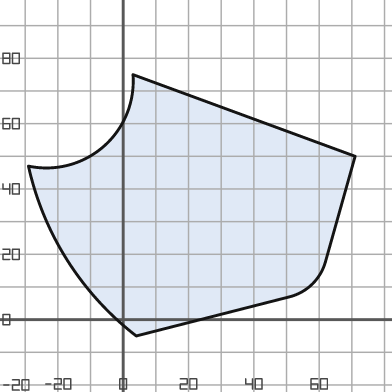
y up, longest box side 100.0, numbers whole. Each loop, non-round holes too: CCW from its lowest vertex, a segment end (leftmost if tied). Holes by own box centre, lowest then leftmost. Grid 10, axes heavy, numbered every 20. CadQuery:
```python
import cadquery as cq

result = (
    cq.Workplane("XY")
    .moveTo(4.0, -5.0)
    .lineTo(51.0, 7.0)
    .threePointArc((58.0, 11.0), (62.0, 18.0))
    .lineTo(71.0, 50.0)
    .lineTo(3.0, 75.0)
    .threePointArc((-6.0, 53.0), (-29.0, 47.0))
    .threePointArc((-17.0, 18.0), (4.0, -5.0))
    .close()
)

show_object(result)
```